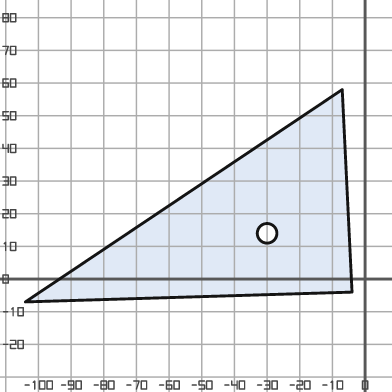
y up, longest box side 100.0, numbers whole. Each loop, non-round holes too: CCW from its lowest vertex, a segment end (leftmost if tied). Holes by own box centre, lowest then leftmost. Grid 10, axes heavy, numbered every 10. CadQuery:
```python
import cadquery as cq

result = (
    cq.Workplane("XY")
    .moveTo(-104.0, -7.0)
    .lineTo(-4.0, -4.0)
    .lineTo(-7.0, 58.0)
    .close()
    .moveTo(-30.0, 14.0)
    .circle(3.0)
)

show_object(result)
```